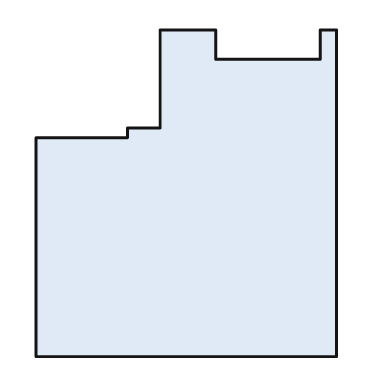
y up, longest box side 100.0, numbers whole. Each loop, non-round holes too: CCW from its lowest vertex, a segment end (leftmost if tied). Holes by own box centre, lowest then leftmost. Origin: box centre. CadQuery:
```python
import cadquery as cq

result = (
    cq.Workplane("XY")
    .moveTo(-46.0, -50.0)
    .lineTo(46.0, -50.0)
    .lineTo(46.0, 50.0)
    .lineTo(41.0, 50.0)
    .lineTo(41.0, 41.0)
    .lineTo(9.0, 41.0)
    .lineTo(9.0, 50.0)
    .lineTo(-8.0, 50.0)
    .lineTo(-8.0, 20.0)
    .lineTo(-18.0, 20.0)
    .lineTo(-18.0, 17.0)
    .lineTo(-46.0, 17.0)
    .close()
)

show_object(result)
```